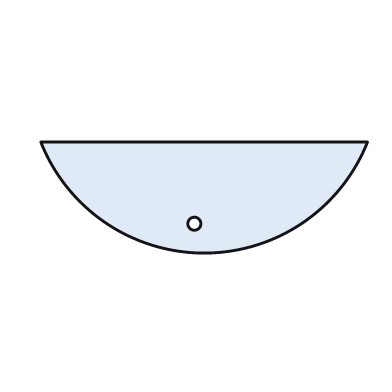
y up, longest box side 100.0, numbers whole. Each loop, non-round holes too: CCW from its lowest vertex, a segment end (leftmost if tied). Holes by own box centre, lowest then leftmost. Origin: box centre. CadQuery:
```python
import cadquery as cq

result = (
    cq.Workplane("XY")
    .moveTo(-50.0, 17.0)
    .threePointArc((0.0, -17.0), (50.0, 17.0))
    .close()
    .moveTo(-3.0, -8.0)
    .circle(2.0)
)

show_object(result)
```